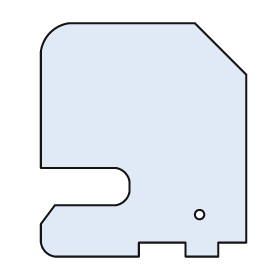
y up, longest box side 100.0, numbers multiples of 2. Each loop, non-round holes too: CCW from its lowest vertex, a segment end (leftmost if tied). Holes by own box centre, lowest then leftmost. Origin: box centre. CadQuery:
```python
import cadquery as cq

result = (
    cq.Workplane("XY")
    .moveTo(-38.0, -50.0)
    .lineTo(-2.0, -50.0)
    .lineTo(-2.0, -44.0)
    .lineTo(18.0, -44.0)
    .lineTo(18.0, -50.0)
    .lineTo(32.0, -50.0)
    .lineTo(32.0, -44.0)
    .lineTo(44.0, -44.0)
    .lineTo(44.0, 28.0)
    .lineTo(22.0, 50.0)
    .lineTo(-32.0, 50.0)
    .threePointArc((-40.0, 46.0), (-44.0, 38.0))
    .lineTo(-44.0, -12.0)
    .lineTo(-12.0, -12.0)
    .threePointArc((-8.0, -14.0), (-6.0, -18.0))
    .lineTo(-6.0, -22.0)
    .threePointArc((-8.0, -26.0), (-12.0, -28.0))
    .lineTo(-38.0, -28.0)
    .lineTo(-44.0, -36.0)
    .lineTo(-44.0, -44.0)
    .threePointArc((-42.0, -48.0), (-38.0, -50.0))
    .close()
    .moveTo(24.0, -32.0)
    .circle(2.0)
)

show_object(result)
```